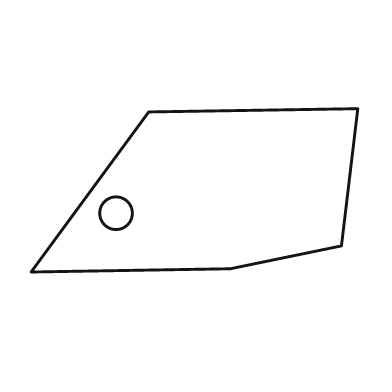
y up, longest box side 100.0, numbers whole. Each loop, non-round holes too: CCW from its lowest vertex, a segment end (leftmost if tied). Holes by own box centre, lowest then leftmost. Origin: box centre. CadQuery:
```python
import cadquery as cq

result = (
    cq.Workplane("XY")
    .moveTo(-50.0, -25.0)
    .lineTo(11.0, -24.0)
    .lineTo(45.0, -17.0)
    .lineTo(50.0, 25.0)
    .lineTo(-14.0, 24.0)
    .close()
    .moveTo(-24.0, -7.0)
    .circle(5.0)
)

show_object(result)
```